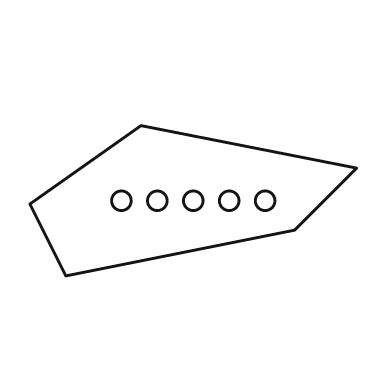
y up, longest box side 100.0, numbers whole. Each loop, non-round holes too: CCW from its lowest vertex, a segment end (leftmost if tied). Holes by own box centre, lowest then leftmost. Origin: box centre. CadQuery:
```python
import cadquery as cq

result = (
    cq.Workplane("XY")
    .moveTo(-39.0, -23.0)
    .lineTo(31.0, -9.0)
    .lineTo(50.0, 10.0)
    .lineTo(-16.0, 23.0)
    .lineTo(-50.0, -1.0)
    .close()
    .moveTo(-22.0, 0.0)
    .circle(3.0)
    .moveTo(-11.0, 0.0)
    .circle(3.0)
    .moveTo(0.0, 0.0)
    .circle(3.0)
    .moveTo(11.0, 0.0)
    .circle(3.0)
    .moveTo(22.0, 0.0)
    .circle(3.0)
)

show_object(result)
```